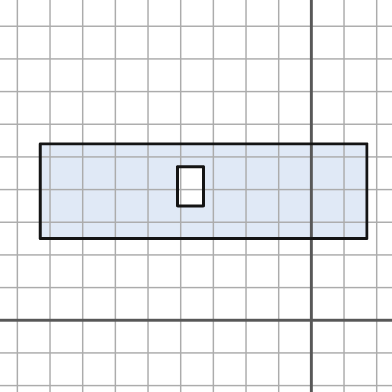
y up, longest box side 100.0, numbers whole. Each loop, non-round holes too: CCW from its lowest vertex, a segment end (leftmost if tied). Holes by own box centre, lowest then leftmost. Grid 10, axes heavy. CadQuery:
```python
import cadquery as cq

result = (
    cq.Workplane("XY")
    .moveTo(-83.0, 25.0)
    .lineTo(17.0, 25.0)
    .lineTo(17.0, 54.0)
    .lineTo(-83.0, 54.0)
    .close()
    .moveTo(-41.0, 35.0)
    .lineTo(-33.0, 35.0)
    .lineTo(-33.0, 47.0)
    .lineTo(-41.0, 47.0)
    .close()
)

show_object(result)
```